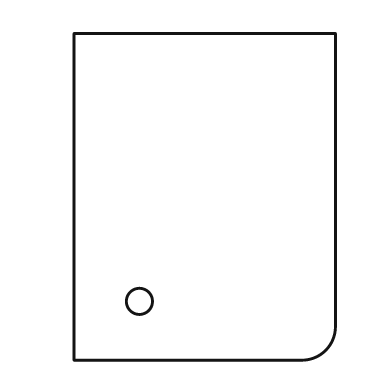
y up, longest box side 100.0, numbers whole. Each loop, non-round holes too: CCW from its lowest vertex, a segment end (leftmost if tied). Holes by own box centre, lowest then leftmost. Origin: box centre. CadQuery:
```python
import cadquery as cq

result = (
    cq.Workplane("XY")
    .moveTo(-40.0, -50.0)
    .lineTo(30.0, -50.0)
    .threePointArc((37.0, -47.0), (40.0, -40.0))
    .lineTo(40.0, 50.0)
    .lineTo(-40.0, 50.0)
    .close()
    .moveTo(-20.0, -32.0)
    .circle(4.0)
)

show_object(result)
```